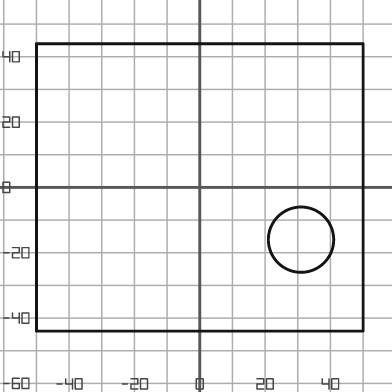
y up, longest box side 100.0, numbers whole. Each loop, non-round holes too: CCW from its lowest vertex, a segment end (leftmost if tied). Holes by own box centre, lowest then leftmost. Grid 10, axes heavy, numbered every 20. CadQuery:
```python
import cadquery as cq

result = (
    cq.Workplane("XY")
    .moveTo(-50.0, -44.0)
    .lineTo(50.0, -44.0)
    .lineTo(50.0, 44.0)
    .lineTo(-50.0, 44.0)
    .close()
    .moveTo(31.0, -16.0)
    .circle(10.0)
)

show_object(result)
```